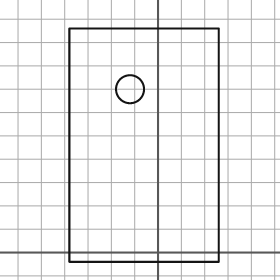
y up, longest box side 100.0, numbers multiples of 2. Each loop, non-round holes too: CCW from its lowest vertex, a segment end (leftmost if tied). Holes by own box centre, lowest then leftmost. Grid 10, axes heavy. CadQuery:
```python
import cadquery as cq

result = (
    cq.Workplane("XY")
    .moveTo(-38.0, -4.0)
    .lineTo(26.0, -4.0)
    .lineTo(26.0, 96.0)
    .lineTo(-38.0, 96.0)
    .close()
    .moveTo(-12.0, 70.0)
    .circle(6.0)
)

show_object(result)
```